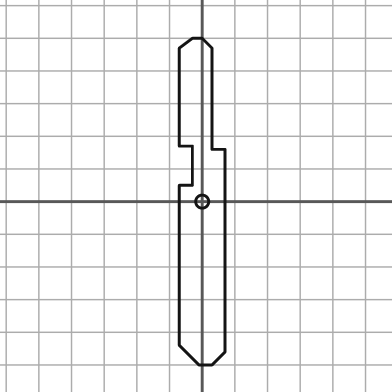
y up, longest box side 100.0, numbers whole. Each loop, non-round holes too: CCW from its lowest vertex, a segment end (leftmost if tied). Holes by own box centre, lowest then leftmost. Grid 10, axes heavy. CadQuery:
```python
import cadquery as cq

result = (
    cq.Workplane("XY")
    .moveTo(-1.0, -50.0)
    .lineTo(3.0, -50.0)
    .lineTo(7.0, -46.0)
    .lineTo(7.0, 16.0)
    .lineTo(3.0, 16.0)
    .lineTo(3.0, 47.0)
    .lineTo(0.0, 50.0)
    .lineTo(-3.0, 50.0)
    .lineTo(-7.0, 47.0)
    .lineTo(-7.0, 17.0)
    .lineTo(-3.0, 17.0)
    .lineTo(-3.0, 5.0)
    .lineTo(-7.0, 5.0)
    .lineTo(-7.0, -44.0)
    .close()
    .moveTo(0.0, 0.0)
    .circle(2.0)
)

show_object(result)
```